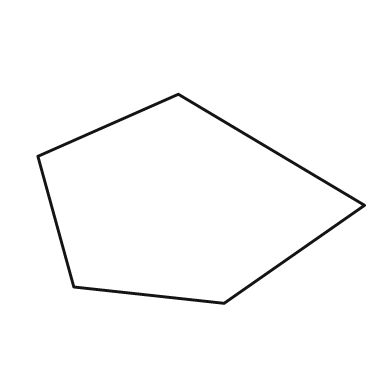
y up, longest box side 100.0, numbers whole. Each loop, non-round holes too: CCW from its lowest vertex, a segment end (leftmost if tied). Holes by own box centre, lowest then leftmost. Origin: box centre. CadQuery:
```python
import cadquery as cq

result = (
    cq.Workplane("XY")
    .moveTo(7.0, -32.0)
    .lineTo(50.0, -2.0)
    .lineTo(-7.0, 32.0)
    .lineTo(-50.0, 13.0)
    .lineTo(-39.0, -27.0)
    .close()
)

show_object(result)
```